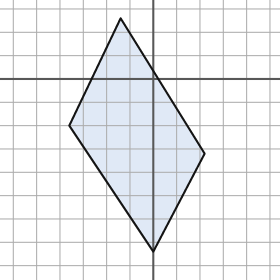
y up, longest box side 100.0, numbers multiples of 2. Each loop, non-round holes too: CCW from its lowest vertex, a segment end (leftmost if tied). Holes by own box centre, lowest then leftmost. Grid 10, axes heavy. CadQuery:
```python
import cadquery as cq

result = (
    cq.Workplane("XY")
    .moveTo(0.0, -74.0)
    .lineTo(22.0, -32.0)
    .lineTo(-14.0, 26.0)
    .lineTo(-36.0, -20.0)
    .close()
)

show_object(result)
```